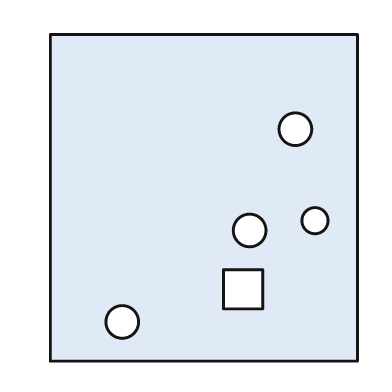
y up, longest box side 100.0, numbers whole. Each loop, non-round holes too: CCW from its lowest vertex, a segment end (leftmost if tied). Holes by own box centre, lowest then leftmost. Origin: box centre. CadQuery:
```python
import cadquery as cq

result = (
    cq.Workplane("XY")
    .moveTo(-47.0, -50.0)
    .lineTo(47.0, -50.0)
    .lineTo(47.0, 50.0)
    .lineTo(-47.0, 50.0)
    .close()
    .moveTo(-25.0, -38.0)
    .circle(5.0)
    .moveTo(6.0, -34.0)
    .lineTo(18.0, -34.0)
    .lineTo(18.0, -22.0)
    .lineTo(6.0, -22.0)
    .close()
    .moveTo(14.0, -10.0)
    .circle(5.0)
    .moveTo(34.0, -7.0)
    .circle(4.0)
    .moveTo(28.0, 21.0)
    .circle(5.0)
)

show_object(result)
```